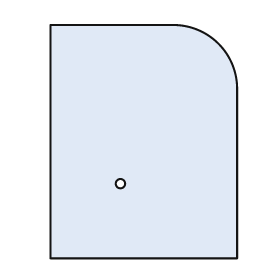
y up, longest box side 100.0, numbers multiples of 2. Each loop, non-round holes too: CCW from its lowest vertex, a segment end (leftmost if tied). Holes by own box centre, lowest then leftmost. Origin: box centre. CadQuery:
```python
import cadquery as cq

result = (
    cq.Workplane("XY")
    .moveTo(-40.0, -50.0)
    .lineTo(40.0, -50.0)
    .lineTo(40.0, 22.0)
    .threePointArc((32.0, 42.0), (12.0, 50.0))
    .lineTo(-40.0, 50.0)
    .close()
    .moveTo(-10.0, -18.0)
    .circle(2.0)
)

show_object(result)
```